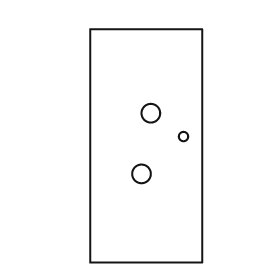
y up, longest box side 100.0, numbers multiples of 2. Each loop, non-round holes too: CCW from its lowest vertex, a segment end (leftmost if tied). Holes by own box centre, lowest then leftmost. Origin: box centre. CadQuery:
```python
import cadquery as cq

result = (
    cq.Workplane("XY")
    .moveTo(-24.0, -50.0)
    .lineTo(24.0, -50.0)
    .lineTo(24.0, 50.0)
    .lineTo(-24.0, 50.0)
    .close()
    .moveTo(-2.0, -12.0)
    .circle(4.0)
    .moveTo(16.0, 4.0)
    .circle(2.0)
    .moveTo(2.0, 14.0)
    .circle(4.0)
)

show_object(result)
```